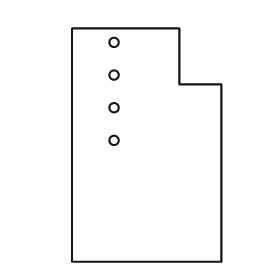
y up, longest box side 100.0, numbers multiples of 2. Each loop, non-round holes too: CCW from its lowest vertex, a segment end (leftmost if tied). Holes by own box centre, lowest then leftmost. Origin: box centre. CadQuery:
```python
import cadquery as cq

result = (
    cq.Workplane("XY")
    .moveTo(-32.0, -50.0)
    .lineTo(32.0, -50.0)
    .lineTo(32.0, 26.0)
    .lineTo(14.0, 26.0)
    .lineTo(14.0, 50.0)
    .lineTo(-32.0, 50.0)
    .close()
    .moveTo(-14.0, 2.0)
    .circle(2.0)
    .moveTo(-14.0, 16.0)
    .circle(2.0)
    .moveTo(-14.0, 30.0)
    .circle(2.0)
    .moveTo(-14.0, 44.0)
    .circle(2.0)
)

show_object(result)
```